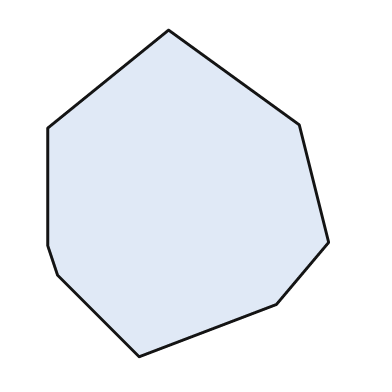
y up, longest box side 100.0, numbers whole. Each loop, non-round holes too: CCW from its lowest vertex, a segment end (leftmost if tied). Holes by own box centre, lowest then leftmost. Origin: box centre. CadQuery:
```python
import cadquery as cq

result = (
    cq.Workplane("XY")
    .moveTo(-15.0, -50.0)
    .lineTo(27.0, -34.0)
    .lineTo(43.0, -15.0)
    .lineTo(34.0, 21.0)
    .lineTo(-6.0, 50.0)
    .lineTo(-43.0, 20.0)
    .lineTo(-43.0, -16.0)
    .lineTo(-40.0, -25.0)
    .close()
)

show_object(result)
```